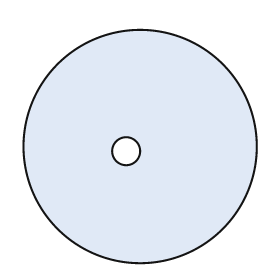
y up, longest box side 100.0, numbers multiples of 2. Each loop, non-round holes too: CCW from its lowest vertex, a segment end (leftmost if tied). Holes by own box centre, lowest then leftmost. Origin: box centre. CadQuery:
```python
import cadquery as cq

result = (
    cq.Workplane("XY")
    .moveTo(0.0, 0.0)
    .circle(50.0)
    .moveTo(-6.0, -2.0)
    .circle(6.0)
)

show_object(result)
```